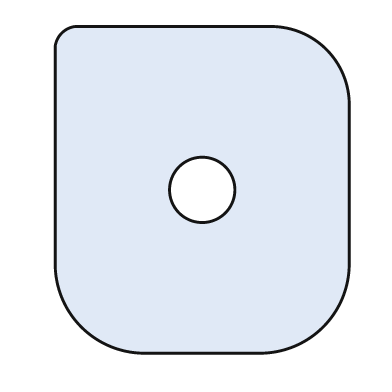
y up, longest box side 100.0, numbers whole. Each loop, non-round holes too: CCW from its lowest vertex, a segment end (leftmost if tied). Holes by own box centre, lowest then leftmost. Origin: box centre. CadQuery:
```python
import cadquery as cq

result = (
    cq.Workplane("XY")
    .moveTo(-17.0, -50.0)
    .lineTo(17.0, -50.0)
    .threePointArc((37.0, -42.0), (45.0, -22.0))
    .lineTo(45.0, 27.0)
    .threePointArc((38.0, 43.0), (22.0, 50.0))
    .lineTo(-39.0, 50.0)
    .threePointArc((-43.0, 48.0), (-45.0, 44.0))
    .lineTo(-45.0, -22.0)
    .threePointArc((-37.0, -42.0), (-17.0, -50.0))
    .close()
    .moveTo(0.0, 0.0)
    .circle(10.0)
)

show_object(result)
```